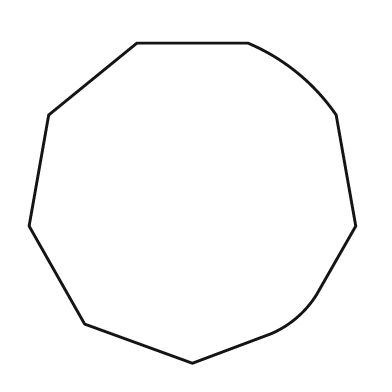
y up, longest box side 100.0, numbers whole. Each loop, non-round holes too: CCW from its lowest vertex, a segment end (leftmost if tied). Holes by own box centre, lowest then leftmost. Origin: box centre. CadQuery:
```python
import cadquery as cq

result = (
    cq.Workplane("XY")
    .moveTo(0.0, -49.0)
    .lineTo(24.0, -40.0)
    .threePointArc((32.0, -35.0), (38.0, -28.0))
    .lineTo(50.0, -7.0)
    .lineTo(44.0, 27.0)
    .threePointArc((32.0, 40.0), (17.0, 49.0))
    .lineTo(-17.0, 49.0)
    .lineTo(-44.0, 27.0)
    .lineTo(-50.0, -7.0)
    .lineTo(-33.0, -37.0)
    .close()
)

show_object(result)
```